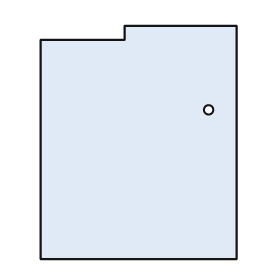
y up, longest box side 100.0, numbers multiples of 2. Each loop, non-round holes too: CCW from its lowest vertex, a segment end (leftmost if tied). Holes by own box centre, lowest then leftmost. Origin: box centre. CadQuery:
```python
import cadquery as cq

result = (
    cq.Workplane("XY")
    .moveTo(-42.0, -50.0)
    .lineTo(42.0, -50.0)
    .lineTo(42.0, 50.0)
    .lineTo(-6.0, 50.0)
    .lineTo(-6.0, 44.0)
    .lineTo(-42.0, 44.0)
    .close()
    .moveTo(30.0, 14.0)
    .circle(2.0)
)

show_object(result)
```